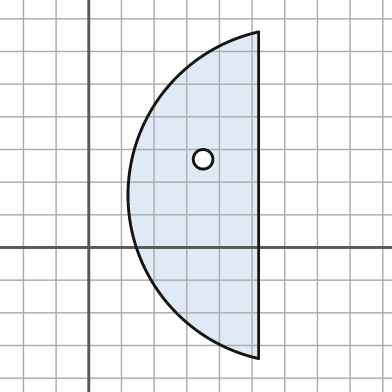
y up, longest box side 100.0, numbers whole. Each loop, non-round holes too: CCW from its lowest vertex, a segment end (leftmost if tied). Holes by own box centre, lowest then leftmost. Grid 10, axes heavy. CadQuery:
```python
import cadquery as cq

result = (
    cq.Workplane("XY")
    .moveTo(52.0, -34.0)
    .lineTo(52.0, 66.0)
    .threePointArc((12.0, 16.0), (52.0, -34.0))
    .close()
    .moveTo(35.0, 27.0)
    .circle(3.0)
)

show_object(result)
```